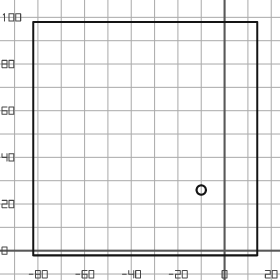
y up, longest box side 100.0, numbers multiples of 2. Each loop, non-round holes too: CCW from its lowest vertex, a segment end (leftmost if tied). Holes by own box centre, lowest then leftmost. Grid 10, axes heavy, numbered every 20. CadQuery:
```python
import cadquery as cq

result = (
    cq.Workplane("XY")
    .moveTo(-82.0, -2.0)
    .lineTo(14.0, -2.0)
    .lineTo(14.0, 98.0)
    .lineTo(-82.0, 98.0)
    .close()
    .moveTo(-10.0, 26.0)
    .circle(2.0)
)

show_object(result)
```